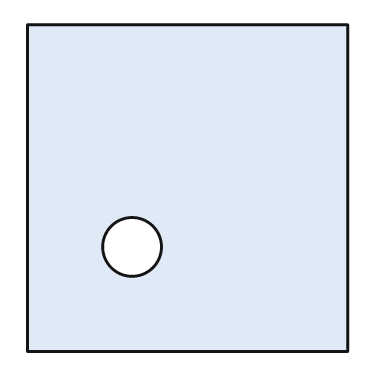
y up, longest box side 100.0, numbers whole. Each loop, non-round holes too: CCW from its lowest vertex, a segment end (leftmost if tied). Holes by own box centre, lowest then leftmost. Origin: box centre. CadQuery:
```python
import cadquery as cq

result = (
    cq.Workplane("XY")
    .moveTo(-49.0, -50.0)
    .lineTo(49.0, -50.0)
    .lineTo(49.0, 50.0)
    .lineTo(-49.0, 50.0)
    .close()
    .moveTo(-17.0, -18.0)
    .circle(9.0)
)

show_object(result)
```